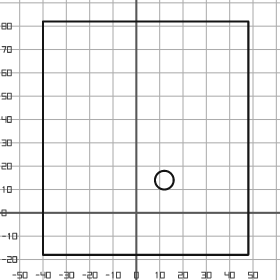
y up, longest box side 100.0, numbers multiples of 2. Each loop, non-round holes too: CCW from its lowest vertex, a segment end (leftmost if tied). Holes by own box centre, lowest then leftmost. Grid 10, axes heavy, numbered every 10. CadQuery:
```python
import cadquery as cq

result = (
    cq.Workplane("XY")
    .moveTo(-40.0, -18.0)
    .lineTo(48.0, -18.0)
    .lineTo(48.0, 82.0)
    .lineTo(-40.0, 82.0)
    .close()
    .moveTo(12.0, 14.0)
    .circle(4.0)
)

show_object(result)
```